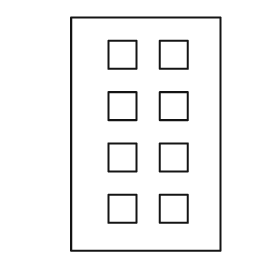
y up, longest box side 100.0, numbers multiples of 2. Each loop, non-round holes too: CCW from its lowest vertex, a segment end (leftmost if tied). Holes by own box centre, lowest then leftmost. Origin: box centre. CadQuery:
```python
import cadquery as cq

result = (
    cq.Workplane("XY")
    .moveTo(-32.0, -50.0)
    .lineTo(32.0, -50.0)
    .lineTo(32.0, 50.0)
    .lineTo(-32.0, 50.0)
    .close()
    .moveTo(-16.0, -38.0)
    .lineTo(-4.0, -38.0)
    .lineTo(-4.0, -26.0)
    .lineTo(-16.0, -26.0)
    .close()
    .moveTo(6.0, -38.0)
    .lineTo(18.0, -38.0)
    .lineTo(18.0, -26.0)
    .lineTo(6.0, -26.0)
    .close()
    .moveTo(-16.0, -16.0)
    .lineTo(-4.0, -16.0)
    .lineTo(-4.0, -4.0)
    .lineTo(-16.0, -4.0)
    .close()
    .moveTo(6.0, -16.0)
    .lineTo(18.0, -16.0)
    .lineTo(18.0, -4.0)
    .lineTo(6.0, -4.0)
    .close()
    .moveTo(-16.0, 6.0)
    .lineTo(-4.0, 6.0)
    .lineTo(-4.0, 18.0)
    .lineTo(-16.0, 18.0)
    .close()
    .moveTo(6.0, 6.0)
    .lineTo(18.0, 6.0)
    .lineTo(18.0, 18.0)
    .lineTo(6.0, 18.0)
    .close()
    .moveTo(-16.0, 28.0)
    .lineTo(-4.0, 28.0)
    .lineTo(-4.0, 40.0)
    .lineTo(-16.0, 40.0)
    .close()
    .moveTo(6.0, 28.0)
    .lineTo(18.0, 28.0)
    .lineTo(18.0, 40.0)
    .lineTo(6.0, 40.0)
    .close()
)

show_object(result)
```